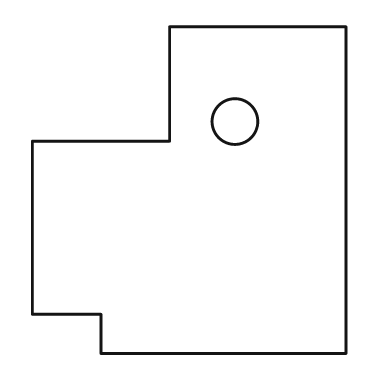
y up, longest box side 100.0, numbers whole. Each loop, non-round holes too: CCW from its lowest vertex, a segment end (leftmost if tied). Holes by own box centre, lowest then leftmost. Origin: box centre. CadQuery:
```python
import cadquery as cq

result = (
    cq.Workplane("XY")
    .moveTo(-27.0, -50.0)
    .lineTo(48.0, -50.0)
    .lineTo(48.0, 50.0)
    .lineTo(-6.0, 50.0)
    .lineTo(-6.0, 15.0)
    .lineTo(-48.0, 15.0)
    .lineTo(-48.0, -38.0)
    .lineTo(-27.0, -38.0)
    .close()
    .moveTo(14.0, 21.0)
    .circle(7.0)
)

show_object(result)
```